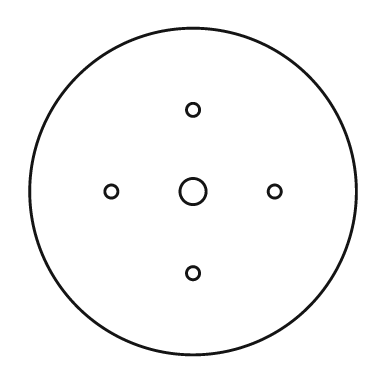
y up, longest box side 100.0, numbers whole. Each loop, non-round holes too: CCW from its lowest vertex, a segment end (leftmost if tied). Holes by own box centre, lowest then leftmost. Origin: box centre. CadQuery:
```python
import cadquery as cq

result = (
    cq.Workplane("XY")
    .moveTo(0.0, 0.0)
    .circle(50.0)
    .moveTo(0.0, -25.0)
    .circle(2.0)
    .moveTo(-25.0, 0.0)
    .circle(2.0)
    .moveTo(0.0, 0.0)
    .circle(4.0)
    .moveTo(25.0, 0.0)
    .circle(2.0)
    .moveTo(0.0, 25.0)
    .circle(2.0)
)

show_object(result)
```